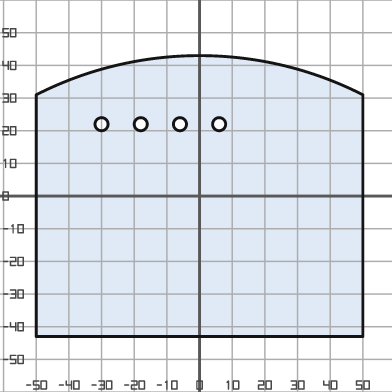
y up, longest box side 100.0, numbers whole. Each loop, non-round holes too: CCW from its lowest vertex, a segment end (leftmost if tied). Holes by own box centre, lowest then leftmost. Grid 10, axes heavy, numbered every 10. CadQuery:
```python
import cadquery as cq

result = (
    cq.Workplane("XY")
    .moveTo(-50.0, -43.0)
    .lineTo(50.0, -43.0)
    .lineTo(50.0, 31.0)
    .threePointArc((0.0, 43.0), (-50.0, 31.0))
    .close()
    .moveTo(-30.0, 22.0)
    .circle(2.0)
    .moveTo(-18.0, 22.0)
    .circle(2.0)
    .moveTo(-6.0, 22.0)
    .circle(2.0)
    .moveTo(6.0, 22.0)
    .circle(2.0)
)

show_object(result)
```